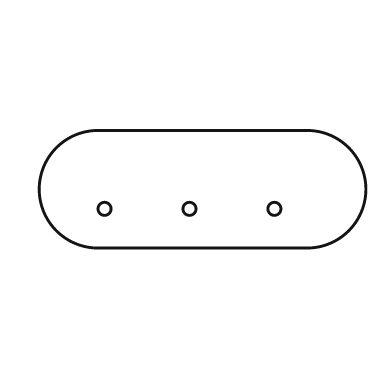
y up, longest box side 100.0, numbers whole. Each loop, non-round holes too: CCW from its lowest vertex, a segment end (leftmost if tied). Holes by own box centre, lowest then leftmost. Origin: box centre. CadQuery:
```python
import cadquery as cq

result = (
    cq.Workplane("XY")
    .moveTo(-32.0, -18.0)
    .lineTo(32.0, -18.0)
    .threePointArc((50.0, 0.0), (32.0, 18.0))
    .lineTo(-32.0, 18.0)
    .threePointArc((-50.0, 0.0), (-32.0, -18.0))
    .close()
    .moveTo(-30.0, -6.0)
    .circle(2.0)
    .moveTo(-4.0, -6.0)
    .circle(2.0)
    .moveTo(22.0, -6.0)
    .circle(2.0)
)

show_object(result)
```